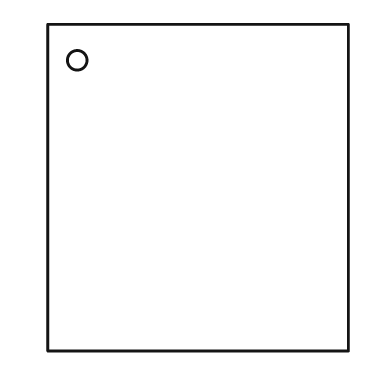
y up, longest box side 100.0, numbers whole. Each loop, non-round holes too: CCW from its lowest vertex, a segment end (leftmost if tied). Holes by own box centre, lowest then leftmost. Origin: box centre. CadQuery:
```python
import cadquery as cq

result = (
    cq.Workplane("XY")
    .moveTo(-46.0, -50.0)
    .lineTo(46.0, -50.0)
    .lineTo(46.0, 50.0)
    .lineTo(-46.0, 50.0)
    .close()
    .moveTo(-37.0, 39.0)
    .circle(3.0)
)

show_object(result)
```